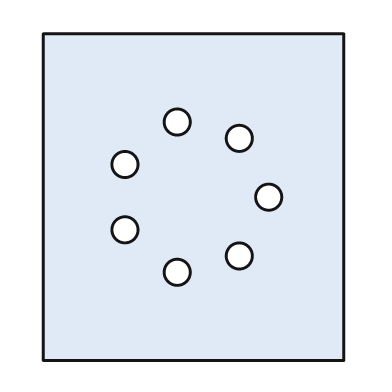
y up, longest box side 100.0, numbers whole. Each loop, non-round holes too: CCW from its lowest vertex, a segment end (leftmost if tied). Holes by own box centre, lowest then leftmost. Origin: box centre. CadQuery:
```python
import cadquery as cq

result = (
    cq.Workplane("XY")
    .moveTo(-46.0, -50.0)
    .lineTo(46.0, -50.0)
    .lineTo(46.0, 50.0)
    .lineTo(-46.0, 50.0)
    .close()
    .moveTo(-5.0, -23.0)
    .circle(4.0)
    .moveTo(14.0, -18.0)
    .circle(4.0)
    .moveTo(-21.0, -10.0)
    .circle(4.0)
    .moveTo(23.0, 0.0)
    .circle(4.0)
    .moveTo(-21.0, 10.0)
    .circle(4.0)
    .moveTo(14.0, 18.0)
    .circle(4.0)
    .moveTo(-5.0, 23.0)
    .circle(4.0)
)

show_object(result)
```